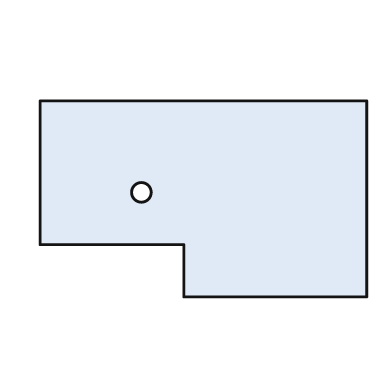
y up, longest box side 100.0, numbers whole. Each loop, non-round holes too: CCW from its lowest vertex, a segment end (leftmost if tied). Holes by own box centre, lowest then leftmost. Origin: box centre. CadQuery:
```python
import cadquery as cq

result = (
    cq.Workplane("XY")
    .moveTo(-6.0, -30.0)
    .lineTo(50.0, -30.0)
    .lineTo(50.0, 30.0)
    .lineTo(-50.0, 30.0)
    .lineTo(-50.0, -14.0)
    .lineTo(-6.0, -14.0)
    .close()
    .moveTo(-19.0, 2.0)
    .circle(3.0)
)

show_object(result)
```